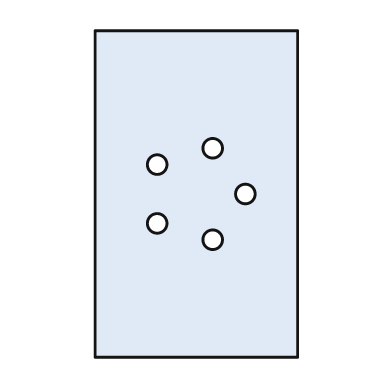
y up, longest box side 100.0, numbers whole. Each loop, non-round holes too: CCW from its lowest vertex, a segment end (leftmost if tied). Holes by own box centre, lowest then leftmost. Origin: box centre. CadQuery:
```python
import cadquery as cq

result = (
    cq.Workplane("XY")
    .moveTo(-31.0, -50.0)
    .lineTo(31.0, -50.0)
    .lineTo(31.0, 50.0)
    .lineTo(-31.0, 50.0)
    .close()
    .moveTo(5.0, -14.0)
    .circle(3.0)
    .moveTo(-12.0, -9.0)
    .circle(3.0)
    .moveTo(15.0, 0.0)
    .circle(3.0)
    .moveTo(-12.0, 9.0)
    .circle(3.0)
    .moveTo(5.0, 14.0)
    .circle(3.0)
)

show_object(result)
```